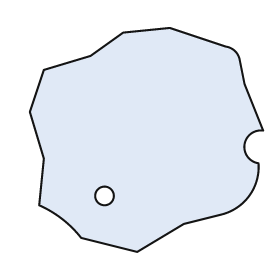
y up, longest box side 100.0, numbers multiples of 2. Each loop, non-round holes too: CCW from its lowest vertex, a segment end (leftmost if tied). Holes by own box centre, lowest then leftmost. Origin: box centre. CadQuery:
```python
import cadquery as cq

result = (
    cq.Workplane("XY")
    .moveTo(-4.0, -48.0)
    .lineTo(16.0, -36.0)
    .lineTo(32.0, -32.0)
    .threePointArc((44.0, -24.0), (48.0, -10.0))
    .threePointArc((42.0, -2.0), (50.0, 4.0))
    .lineTo(42.0, 24.0)
    .lineTo(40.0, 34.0)
    .threePointArc((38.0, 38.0), (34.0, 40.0))
    .lineTo(10.0, 48.0)
    .lineTo(-10.0, 46.0)
    .lineTo(-24.0, 36.0)
    .lineTo(-44.0, 30.0)
    .lineTo(-50.0, 12.0)
    .lineTo(-44.0, -8.0)
    .lineTo(-46.0, -28.0)
    .threePointArc((-36.0, -34.0), (-28.0, -42.0))
    .close()
    .moveTo(-18.0, -24.0)
    .circle(4.0)
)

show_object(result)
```